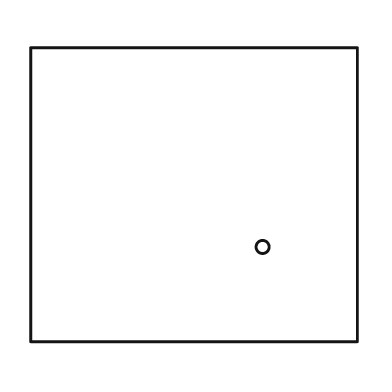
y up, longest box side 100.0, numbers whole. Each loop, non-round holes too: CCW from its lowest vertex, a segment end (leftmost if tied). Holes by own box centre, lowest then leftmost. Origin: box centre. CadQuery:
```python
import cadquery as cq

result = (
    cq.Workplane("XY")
    .moveTo(-50.0, -45.0)
    .lineTo(50.0, -45.0)
    .lineTo(50.0, 45.0)
    .lineTo(-50.0, 45.0)
    .close()
    .moveTo(21.0, -16.0)
    .circle(2.0)
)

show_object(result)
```